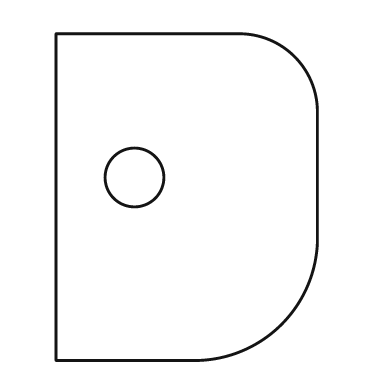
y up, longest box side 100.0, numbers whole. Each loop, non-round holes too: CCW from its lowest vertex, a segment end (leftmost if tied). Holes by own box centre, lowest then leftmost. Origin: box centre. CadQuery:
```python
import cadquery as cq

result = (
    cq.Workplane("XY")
    .moveTo(-40.0, -50.0)
    .lineTo(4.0, -50.0)
    .threePointArc((29.0, -39.0), (40.0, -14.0))
    .lineTo(40.0, 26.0)
    .threePointArc((33.0, 43.0), (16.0, 50.0))
    .lineTo(-40.0, 50.0)
    .close()
    .moveTo(-16.0, 6.0)
    .circle(9.0)
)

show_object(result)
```